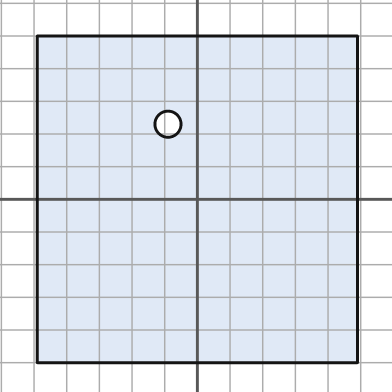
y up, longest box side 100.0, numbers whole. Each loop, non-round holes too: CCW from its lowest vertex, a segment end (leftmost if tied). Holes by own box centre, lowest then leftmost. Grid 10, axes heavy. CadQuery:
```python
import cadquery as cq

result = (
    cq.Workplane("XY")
    .moveTo(-49.0, -50.0)
    .lineTo(49.0, -50.0)
    .lineTo(49.0, 50.0)
    .lineTo(-49.0, 50.0)
    .close()
    .moveTo(-9.0, 23.0)
    .circle(4.0)
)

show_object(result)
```